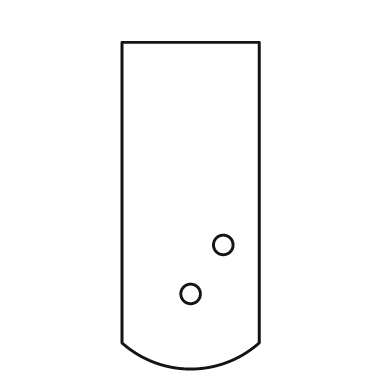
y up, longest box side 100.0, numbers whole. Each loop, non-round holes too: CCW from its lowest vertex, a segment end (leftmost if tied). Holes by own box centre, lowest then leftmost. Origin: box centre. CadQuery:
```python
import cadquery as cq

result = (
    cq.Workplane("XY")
    .moveTo(-21.0, -42.0)
    .threePointArc((0.0, -50.0), (21.0, -42.0))
    .lineTo(21.0, 50.0)
    .lineTo(-21.0, 50.0)
    .close()
    .moveTo(0.0, -27.0)
    .circle(3.0)
    .moveTo(10.0, -12.0)
    .circle(3.0)
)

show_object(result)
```